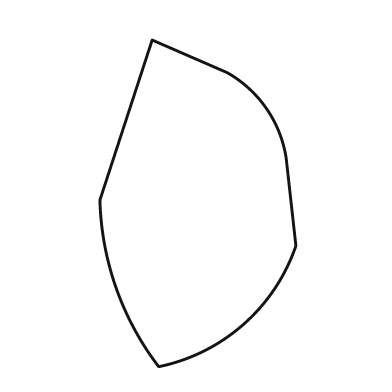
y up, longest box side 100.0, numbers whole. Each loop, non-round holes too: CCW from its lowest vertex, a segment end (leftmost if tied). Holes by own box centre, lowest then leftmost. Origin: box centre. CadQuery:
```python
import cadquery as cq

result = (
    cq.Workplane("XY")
    .moveTo(-12.0, -50.0)
    .threePointArc((14.0, -37.0), (30.0, -13.0))
    .lineTo(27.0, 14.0)
    .threePointArc((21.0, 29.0), (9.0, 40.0))
    .lineTo(-14.0, 50.0)
    .lineTo(-30.0, 1.0)
    .threePointArc((-25.0, -26.0), (-12.0, -50.0))
    .close()
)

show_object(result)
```